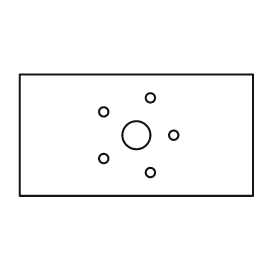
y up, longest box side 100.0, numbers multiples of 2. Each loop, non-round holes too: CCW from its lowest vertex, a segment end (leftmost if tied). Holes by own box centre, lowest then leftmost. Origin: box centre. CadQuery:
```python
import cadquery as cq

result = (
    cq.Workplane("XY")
    .moveTo(-50.0, -26.0)
    .lineTo(50.0, -26.0)
    .lineTo(50.0, 26.0)
    .lineTo(-50.0, 26.0)
    .close()
    .moveTo(6.0, -16.0)
    .circle(2.0)
    .moveTo(-14.0, -10.0)
    .circle(2.0)
    .moveTo(0.0, 0.0)
    .circle(6.0)
    .moveTo(16.0, 0.0)
    .circle(2.0)
    .moveTo(-14.0, 10.0)
    .circle(2.0)
    .moveTo(6.0, 16.0)
    .circle(2.0)
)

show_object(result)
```